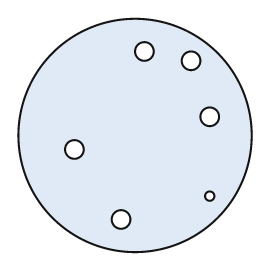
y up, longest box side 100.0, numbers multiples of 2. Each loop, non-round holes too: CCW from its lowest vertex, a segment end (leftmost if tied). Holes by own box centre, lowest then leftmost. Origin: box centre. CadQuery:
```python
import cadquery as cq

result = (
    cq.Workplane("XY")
    .moveTo(0.0, 0.0)
    .circle(50.0)
    .moveTo(-6.0, -36.0)
    .circle(4.0)
    .moveTo(32.0, -26.0)
    .circle(2.0)
    .moveTo(-26.0, -6.0)
    .circle(4.0)
    .moveTo(32.0, 8.0)
    .circle(4.0)
    .moveTo(24.0, 32.0)
    .circle(4.0)
    .moveTo(4.0, 36.0)
    .circle(4.0)
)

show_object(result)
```